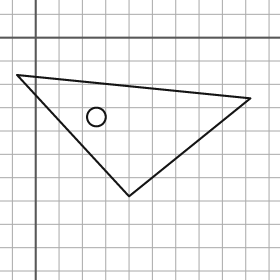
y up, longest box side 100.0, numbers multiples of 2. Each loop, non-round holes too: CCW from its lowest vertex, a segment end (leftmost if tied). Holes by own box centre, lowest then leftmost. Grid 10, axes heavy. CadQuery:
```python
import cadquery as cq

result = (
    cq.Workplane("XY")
    .moveTo(40.0, -68.0)
    .lineTo(92.0, -26.0)
    .lineTo(-8.0, -16.0)
    .close()
    .moveTo(26.0, -34.0)
    .circle(4.0)
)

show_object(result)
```